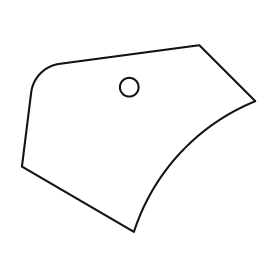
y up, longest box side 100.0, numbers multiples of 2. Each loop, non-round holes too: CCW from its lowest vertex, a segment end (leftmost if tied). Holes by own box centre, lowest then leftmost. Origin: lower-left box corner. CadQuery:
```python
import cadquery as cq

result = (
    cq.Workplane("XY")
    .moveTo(48.0, 0.0)
    .threePointArc((68.0, 34.0), (100.0, 56.0))
    .lineTo(76.0, 80.0)
    .lineTo(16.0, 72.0)
    .threePointArc((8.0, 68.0), (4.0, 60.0))
    .lineTo(0.0, 28.0)
    .close()
    .moveTo(46.0, 62.0)
    .circle(4.0)
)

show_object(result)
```